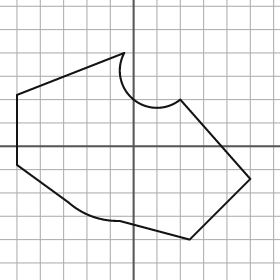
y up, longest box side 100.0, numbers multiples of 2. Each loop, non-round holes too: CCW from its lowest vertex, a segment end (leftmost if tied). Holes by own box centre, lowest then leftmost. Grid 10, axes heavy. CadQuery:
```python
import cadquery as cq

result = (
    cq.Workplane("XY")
    .moveTo(24.0, -40.0)
    .lineTo(50.0, -14.0)
    .lineTo(20.0, 20.0)
    .threePointArc((0.0, 20.0), (-4.0, 40.0))
    .lineTo(-50.0, 22.0)
    .lineTo(-50.0, -8.0)
    .lineTo(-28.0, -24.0)
    .threePointArc((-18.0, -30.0), (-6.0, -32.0))
    .close()
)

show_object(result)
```